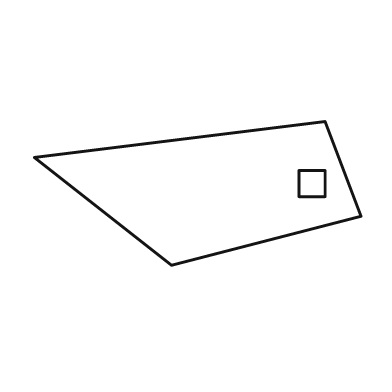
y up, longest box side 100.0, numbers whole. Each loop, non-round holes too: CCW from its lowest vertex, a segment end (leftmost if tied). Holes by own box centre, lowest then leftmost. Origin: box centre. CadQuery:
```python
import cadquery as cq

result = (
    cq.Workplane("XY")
    .moveTo(-8.0, -22.0)
    .lineTo(50.0, -7.0)
    .lineTo(39.0, 22.0)
    .lineTo(-50.0, 11.0)
    .close()
    .moveTo(31.0, -1.0)
    .lineTo(39.0, -1.0)
    .lineTo(39.0, 7.0)
    .lineTo(31.0, 7.0)
    .close()
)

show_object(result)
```